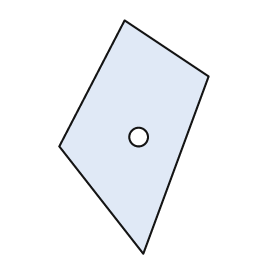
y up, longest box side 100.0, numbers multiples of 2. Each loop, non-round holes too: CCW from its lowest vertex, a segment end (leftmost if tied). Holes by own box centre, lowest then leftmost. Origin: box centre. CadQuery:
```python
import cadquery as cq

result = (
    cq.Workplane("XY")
    .moveTo(4.0, -50.0)
    .lineTo(32.0, 26.0)
    .lineTo(-4.0, 50.0)
    .lineTo(-32.0, -4.0)
    .close()
    .moveTo(2.0, 0.0)
    .circle(4.0)
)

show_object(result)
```